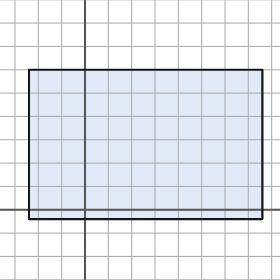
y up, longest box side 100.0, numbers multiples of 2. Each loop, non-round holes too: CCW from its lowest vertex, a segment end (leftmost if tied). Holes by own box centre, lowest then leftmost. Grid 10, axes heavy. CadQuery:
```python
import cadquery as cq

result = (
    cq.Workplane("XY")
    .moveTo(-24.0, -4.0)
    .lineTo(76.0, -4.0)
    .lineTo(76.0, 60.0)
    .lineTo(-24.0, 60.0)
    .close()
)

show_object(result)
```